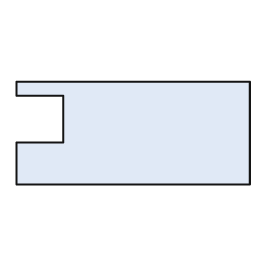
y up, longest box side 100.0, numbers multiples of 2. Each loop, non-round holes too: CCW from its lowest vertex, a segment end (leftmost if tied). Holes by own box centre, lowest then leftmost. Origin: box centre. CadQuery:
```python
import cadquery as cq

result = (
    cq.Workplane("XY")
    .moveTo(-50.0, -22.0)
    .lineTo(50.0, -22.0)
    .lineTo(50.0, 22.0)
    .lineTo(-50.0, 22.0)
    .lineTo(-50.0, 16.0)
    .lineTo(-30.0, 16.0)
    .lineTo(-30.0, -4.0)
    .lineTo(-50.0, -4.0)
    .close()
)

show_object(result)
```